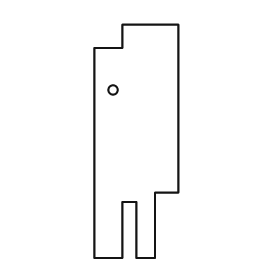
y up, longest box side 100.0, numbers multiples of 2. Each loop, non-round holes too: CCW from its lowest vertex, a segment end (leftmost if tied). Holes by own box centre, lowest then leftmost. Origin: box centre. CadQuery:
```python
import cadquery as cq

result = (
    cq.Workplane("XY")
    .moveTo(-18.0, -50.0)
    .lineTo(-6.0, -50.0)
    .lineTo(-6.0, -26.0)
    .lineTo(0.0, -26.0)
    .lineTo(0.0, -50.0)
    .lineTo(8.0, -50.0)
    .lineTo(8.0, -22.0)
    .lineTo(18.0, -22.0)
    .lineTo(18.0, 50.0)
    .lineTo(-6.0, 50.0)
    .lineTo(-6.0, 40.0)
    .lineTo(-18.0, 40.0)
    .close()
    .moveTo(-10.0, 22.0)
    .circle(2.0)
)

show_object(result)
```